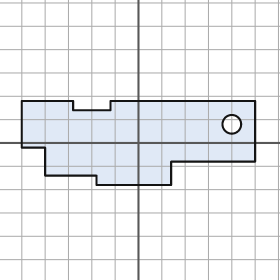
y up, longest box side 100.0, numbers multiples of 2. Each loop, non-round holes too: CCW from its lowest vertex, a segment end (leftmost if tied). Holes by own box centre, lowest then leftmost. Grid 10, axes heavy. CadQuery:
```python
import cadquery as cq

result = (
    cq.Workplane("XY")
    .moveTo(-18.0, -18.0)
    .lineTo(14.0, -18.0)
    .lineTo(14.0, -8.0)
    .lineTo(50.0, -8.0)
    .lineTo(50.0, 18.0)
    .lineTo(-12.0, 18.0)
    .lineTo(-12.0, 14.0)
    .lineTo(-28.0, 14.0)
    .lineTo(-28.0, 18.0)
    .lineTo(-50.0, 18.0)
    .lineTo(-50.0, -2.0)
    .lineTo(-40.0, -2.0)
    .lineTo(-40.0, -14.0)
    .lineTo(-18.0, -14.0)
    .close()
    .moveTo(40.0, 8.0)
    .circle(4.0)
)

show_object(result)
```